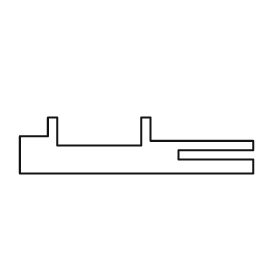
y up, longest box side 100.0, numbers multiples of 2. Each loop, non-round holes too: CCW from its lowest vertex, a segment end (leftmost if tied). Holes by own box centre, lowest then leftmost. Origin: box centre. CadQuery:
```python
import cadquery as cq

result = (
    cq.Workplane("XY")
    .moveTo(-50.0, -12.0)
    .lineTo(50.0, -12.0)
    .lineTo(50.0, -6.0)
    .lineTo(18.0, -6.0)
    .lineTo(18.0, -2.0)
    .lineTo(50.0, -2.0)
    .lineTo(50.0, 2.0)
    .lineTo(6.0, 2.0)
    .lineTo(6.0, 12.0)
    .lineTo(2.0, 12.0)
    .lineTo(2.0, 0.0)
    .lineTo(-34.0, 0.0)
    .lineTo(-34.0, 12.0)
    .lineTo(-38.0, 12.0)
    .lineTo(-38.0, 4.0)
    .lineTo(-50.0, 4.0)
    .close()
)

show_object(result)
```